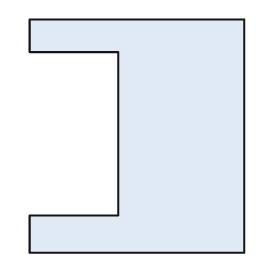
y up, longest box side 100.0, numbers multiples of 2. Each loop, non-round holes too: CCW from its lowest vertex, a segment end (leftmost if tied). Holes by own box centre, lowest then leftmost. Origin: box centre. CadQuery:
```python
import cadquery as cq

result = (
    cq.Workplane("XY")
    .moveTo(-46.0, -50.0)
    .lineTo(46.0, -50.0)
    .lineTo(46.0, 50.0)
    .lineTo(-46.0, 50.0)
    .lineTo(-46.0, 36.0)
    .lineTo(-8.0, 36.0)
    .lineTo(-8.0, -34.0)
    .lineTo(-46.0, -34.0)
    .close()
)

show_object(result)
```